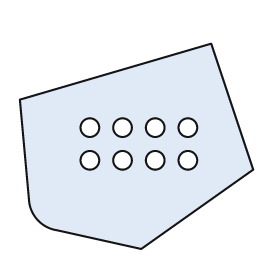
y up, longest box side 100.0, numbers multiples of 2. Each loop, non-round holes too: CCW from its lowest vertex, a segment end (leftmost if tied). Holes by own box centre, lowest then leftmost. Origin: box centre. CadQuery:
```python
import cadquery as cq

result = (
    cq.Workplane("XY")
    .moveTo(2.0, -44.0)
    .lineTo(50.0, -10.0)
    .lineTo(32.0, 44.0)
    .lineTo(-50.0, 20.0)
    .lineTo(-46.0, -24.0)
    .threePointArc((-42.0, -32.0), (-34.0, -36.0))
    .close()
    .moveTo(-20.0, -6.0)
    .circle(4.0)
    .moveTo(-6.0, -6.0)
    .circle(4.0)
    .moveTo(8.0, -6.0)
    .circle(4.0)
    .moveTo(22.0, -6.0)
    .circle(4.0)
    .moveTo(-20.0, 8.0)
    .circle(4.0)
    .moveTo(-6.0, 8.0)
    .circle(4.0)
    .moveTo(8.0, 8.0)
    .circle(4.0)
    .moveTo(22.0, 8.0)
    .circle(4.0)
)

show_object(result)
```